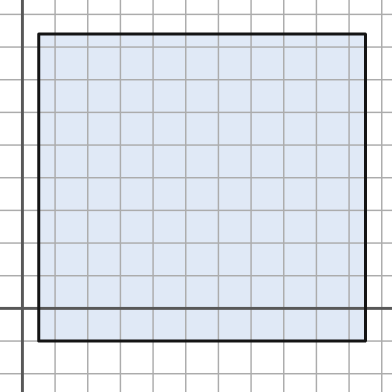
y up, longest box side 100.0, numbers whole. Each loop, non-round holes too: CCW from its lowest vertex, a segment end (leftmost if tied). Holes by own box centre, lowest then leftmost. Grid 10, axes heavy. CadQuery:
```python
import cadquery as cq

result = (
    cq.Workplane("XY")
    .moveTo(5.0, -10.0)
    .lineTo(105.0, -10.0)
    .lineTo(105.0, 84.0)
    .lineTo(5.0, 84.0)
    .close()
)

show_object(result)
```